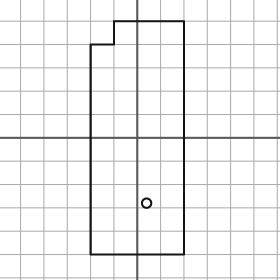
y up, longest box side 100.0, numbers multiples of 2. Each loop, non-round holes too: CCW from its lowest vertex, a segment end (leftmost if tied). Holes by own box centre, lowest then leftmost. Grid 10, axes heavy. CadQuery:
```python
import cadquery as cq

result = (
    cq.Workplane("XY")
    .moveTo(-20.0, -50.0)
    .lineTo(20.0, -50.0)
    .lineTo(20.0, 50.0)
    .lineTo(-10.0, 50.0)
    .lineTo(-10.0, 40.0)
    .lineTo(-20.0, 40.0)
    .close()
    .moveTo(4.0, -28.0)
    .circle(2.0)
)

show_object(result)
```